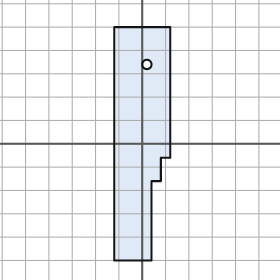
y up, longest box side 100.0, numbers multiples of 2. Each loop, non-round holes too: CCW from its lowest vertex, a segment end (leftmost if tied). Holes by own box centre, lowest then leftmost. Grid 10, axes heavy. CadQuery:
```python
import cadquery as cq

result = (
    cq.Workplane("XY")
    .moveTo(-12.0, -50.0)
    .lineTo(4.0, -50.0)
    .lineTo(4.0, -16.0)
    .lineTo(8.0, -16.0)
    .lineTo(8.0, -6.0)
    .lineTo(12.0, -6.0)
    .lineTo(12.0, 50.0)
    .lineTo(-12.0, 50.0)
    .close()
    .moveTo(2.0, 34.0)
    .circle(2.0)
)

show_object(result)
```